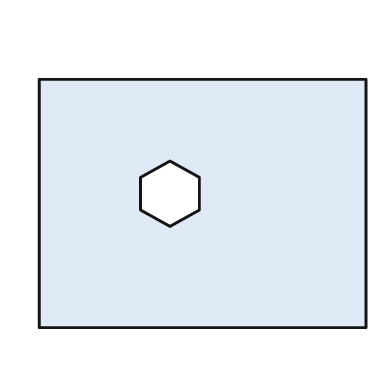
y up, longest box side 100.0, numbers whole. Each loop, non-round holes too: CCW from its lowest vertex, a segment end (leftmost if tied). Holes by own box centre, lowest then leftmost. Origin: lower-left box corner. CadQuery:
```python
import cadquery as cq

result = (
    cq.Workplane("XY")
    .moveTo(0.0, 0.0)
    .lineTo(100.0, 0.0)
    .lineTo(100.0, 76.0)
    .lineTo(0.0, 76.0)
    .close()
    .moveTo(40.0, 31.0)
    .lineTo(49.0, 36.0)
    .lineTo(49.0, 46.0)
    .lineTo(40.0, 51.0)
    .lineTo(31.0, 46.0)
    .lineTo(31.0, 36.0)
    .close()
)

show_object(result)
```